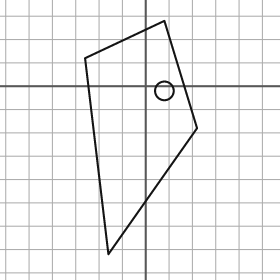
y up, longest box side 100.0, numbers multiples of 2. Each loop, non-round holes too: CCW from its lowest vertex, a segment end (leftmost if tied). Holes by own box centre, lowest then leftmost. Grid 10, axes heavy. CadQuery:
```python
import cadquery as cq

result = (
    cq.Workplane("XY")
    .moveTo(-16.0, -72.0)
    .lineTo(22.0, -18.0)
    .lineTo(8.0, 28.0)
    .lineTo(-26.0, 12.0)
    .close()
    .moveTo(8.0, -2.0)
    .circle(4.0)
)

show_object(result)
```